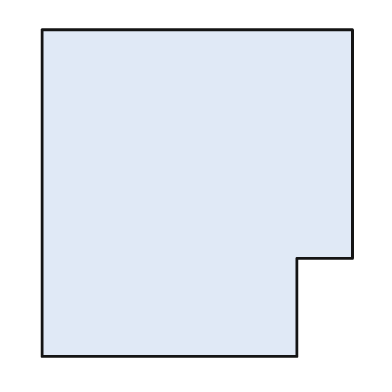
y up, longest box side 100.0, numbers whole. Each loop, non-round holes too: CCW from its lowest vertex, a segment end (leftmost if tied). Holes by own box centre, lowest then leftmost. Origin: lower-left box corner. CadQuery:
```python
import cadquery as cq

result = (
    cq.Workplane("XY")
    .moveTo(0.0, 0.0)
    .lineTo(78.0, 0.0)
    .lineTo(78.0, 30.0)
    .lineTo(95.0, 30.0)
    .lineTo(95.0, 100.0)
    .lineTo(0.0, 100.0)
    .close()
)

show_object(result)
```